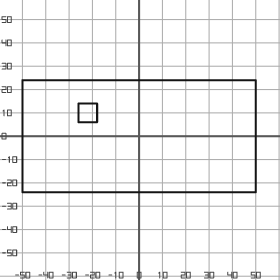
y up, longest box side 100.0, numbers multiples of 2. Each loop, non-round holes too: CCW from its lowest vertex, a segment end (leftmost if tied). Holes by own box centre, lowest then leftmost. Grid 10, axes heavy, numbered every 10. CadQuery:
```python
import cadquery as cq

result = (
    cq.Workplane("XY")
    .moveTo(-50.0, -24.0)
    .lineTo(50.0, -24.0)
    .lineTo(50.0, 24.0)
    .lineTo(-50.0, 24.0)
    .close()
    .moveTo(-26.0, 6.0)
    .lineTo(-18.0, 6.0)
    .lineTo(-18.0, 14.0)
    .lineTo(-26.0, 14.0)
    .close()
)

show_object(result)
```